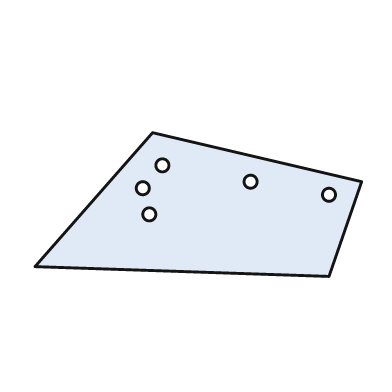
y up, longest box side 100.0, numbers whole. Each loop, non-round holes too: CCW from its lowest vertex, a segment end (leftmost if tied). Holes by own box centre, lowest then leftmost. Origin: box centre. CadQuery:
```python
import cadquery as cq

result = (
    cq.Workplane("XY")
    .moveTo(40.0, -22.0)
    .lineTo(50.0, 7.0)
    .lineTo(-14.0, 22.0)
    .lineTo(-50.0, -19.0)
    .close()
    .moveTo(-15.0, -3.0)
    .circle(2.0)
    .moveTo(40.0, 3.0)
    .circle(2.0)
    .moveTo(-17.0, 5.0)
    .circle(2.0)
    .moveTo(16.0, 7.0)
    .circle(2.0)
    .moveTo(-11.0, 12.0)
    .circle(2.0)
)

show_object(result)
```